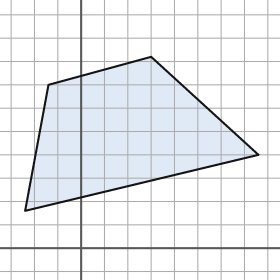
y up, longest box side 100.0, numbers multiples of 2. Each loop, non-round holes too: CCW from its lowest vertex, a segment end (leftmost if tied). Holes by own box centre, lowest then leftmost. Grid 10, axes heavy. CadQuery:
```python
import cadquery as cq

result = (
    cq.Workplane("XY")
    .moveTo(-24.0, 16.0)
    .lineTo(76.0, 40.0)
    .lineTo(30.0, 82.0)
    .lineTo(-14.0, 70.0)
    .close()
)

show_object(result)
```